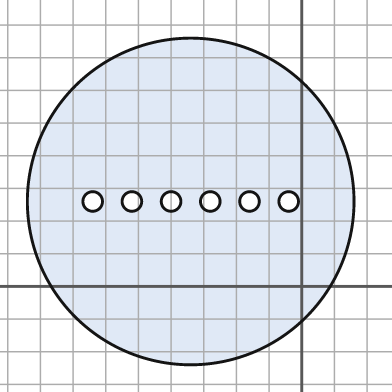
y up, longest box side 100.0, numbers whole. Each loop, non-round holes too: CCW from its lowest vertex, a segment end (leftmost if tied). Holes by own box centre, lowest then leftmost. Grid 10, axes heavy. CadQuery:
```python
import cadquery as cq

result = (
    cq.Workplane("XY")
    .moveTo(-34.0, 26.0)
    .circle(50.0)
    .moveTo(-64.0, 26.0)
    .circle(3.0)
    .moveTo(-52.0, 26.0)
    .circle(3.0)
    .moveTo(-40.0, 26.0)
    .circle(3.0)
    .moveTo(-28.0, 26.0)
    .circle(3.0)
    .moveTo(-16.0, 26.0)
    .circle(3.0)
    .moveTo(-4.0, 26.0)
    .circle(3.0)
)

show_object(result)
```